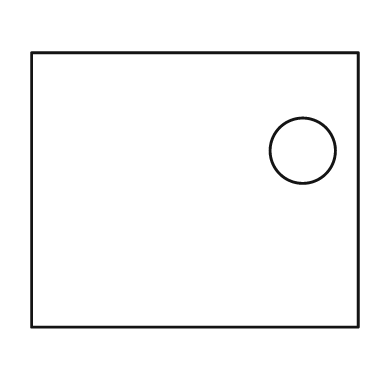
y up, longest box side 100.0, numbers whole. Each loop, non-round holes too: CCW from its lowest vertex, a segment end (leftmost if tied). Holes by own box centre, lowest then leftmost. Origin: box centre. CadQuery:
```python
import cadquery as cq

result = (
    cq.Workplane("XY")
    .moveTo(-50.0, -42.0)
    .lineTo(50.0, -42.0)
    .lineTo(50.0, 42.0)
    .lineTo(-50.0, 42.0)
    .close()
    .moveTo(33.0, 12.0)
    .circle(10.0)
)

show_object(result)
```